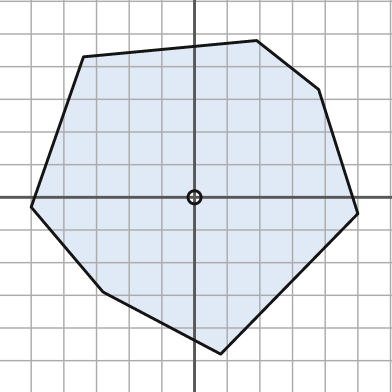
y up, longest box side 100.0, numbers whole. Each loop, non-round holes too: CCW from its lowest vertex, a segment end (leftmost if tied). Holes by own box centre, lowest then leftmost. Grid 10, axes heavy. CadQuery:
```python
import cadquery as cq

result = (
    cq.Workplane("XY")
    .moveTo(8.0, -48.0)
    .lineTo(50.0, -5.0)
    .lineTo(38.0, 33.0)
    .lineTo(19.0, 48.0)
    .lineTo(-34.0, 43.0)
    .lineTo(-50.0, -3.0)
    .lineTo(-28.0, -29.0)
    .close()
    .moveTo(0.0, 0.0)
    .circle(2.0)
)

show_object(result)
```